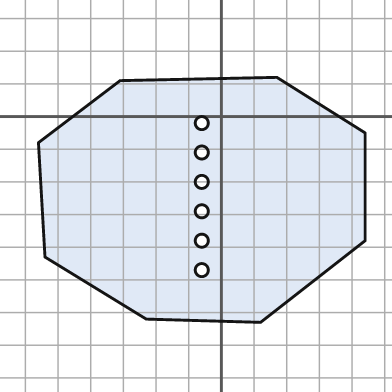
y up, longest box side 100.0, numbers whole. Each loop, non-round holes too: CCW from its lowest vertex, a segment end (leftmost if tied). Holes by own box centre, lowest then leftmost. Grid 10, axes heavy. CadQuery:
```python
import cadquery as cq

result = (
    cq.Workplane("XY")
    .moveTo(12.0, -63.0)
    .lineTo(44.0, -38.0)
    .lineTo(44.0, -5.0)
    .lineTo(17.0, 12.0)
    .lineTo(-31.0, 11.0)
    .lineTo(-56.0, -8.0)
    .lineTo(-54.0, -43.0)
    .lineTo(-23.0, -62.0)
    .close()
    .moveTo(-6.0, -47.0)
    .circle(2.0)
    .moveTo(-6.0, -38.0)
    .circle(2.0)
    .moveTo(-6.0, -29.0)
    .circle(2.0)
    .moveTo(-6.0, -20.0)
    .circle(2.0)
    .moveTo(-6.0, -11.0)
    .circle(2.0)
    .moveTo(-6.0, -2.0)
    .circle(2.0)
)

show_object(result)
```